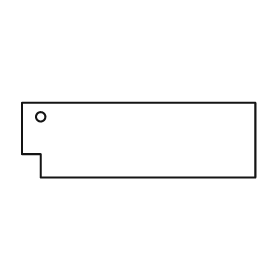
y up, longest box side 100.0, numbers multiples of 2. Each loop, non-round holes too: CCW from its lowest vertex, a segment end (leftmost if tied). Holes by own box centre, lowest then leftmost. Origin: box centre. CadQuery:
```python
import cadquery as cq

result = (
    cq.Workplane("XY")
    .moveTo(-42.0, -16.0)
    .lineTo(50.0, -16.0)
    .lineTo(50.0, 16.0)
    .lineTo(-50.0, 16.0)
    .lineTo(-50.0, -6.0)
    .lineTo(-42.0, -6.0)
    .close()
    .moveTo(-42.0, 10.0)
    .circle(2.0)
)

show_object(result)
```